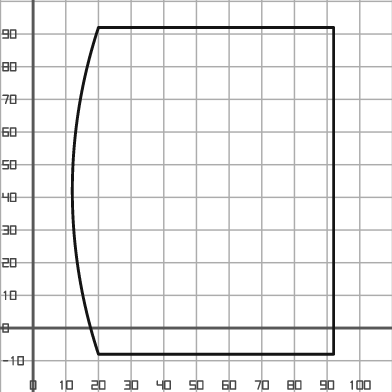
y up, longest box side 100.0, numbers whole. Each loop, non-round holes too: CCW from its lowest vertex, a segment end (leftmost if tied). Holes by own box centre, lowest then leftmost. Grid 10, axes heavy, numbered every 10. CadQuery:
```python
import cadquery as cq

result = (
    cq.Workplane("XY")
    .moveTo(20.0, -8.0)
    .lineTo(92.0, -8.0)
    .lineTo(92.0, 92.0)
    .lineTo(20.0, 92.0)
    .threePointArc((12.0, 42.0), (20.0, -8.0))
    .close()
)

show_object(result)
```